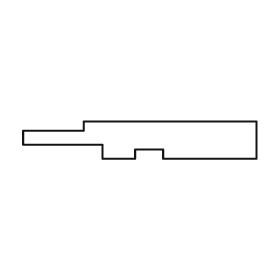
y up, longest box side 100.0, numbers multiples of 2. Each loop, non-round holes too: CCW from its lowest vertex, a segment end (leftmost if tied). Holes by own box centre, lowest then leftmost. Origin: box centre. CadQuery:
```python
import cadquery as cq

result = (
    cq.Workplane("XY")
    .moveTo(-16.0, -8.0)
    .lineTo(-2.0, -8.0)
    .lineTo(-2.0, -4.0)
    .lineTo(10.0, -4.0)
    .lineTo(10.0, -8.0)
    .lineTo(50.0, -8.0)
    .lineTo(50.0, 8.0)
    .lineTo(-24.0, 8.0)
    .lineTo(-24.0, 4.0)
    .lineTo(-50.0, 4.0)
    .lineTo(-50.0, -2.0)
    .lineTo(-16.0, -2.0)
    .close()
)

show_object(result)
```